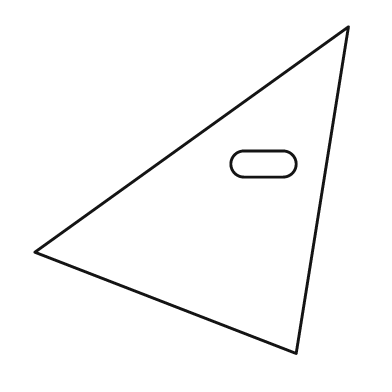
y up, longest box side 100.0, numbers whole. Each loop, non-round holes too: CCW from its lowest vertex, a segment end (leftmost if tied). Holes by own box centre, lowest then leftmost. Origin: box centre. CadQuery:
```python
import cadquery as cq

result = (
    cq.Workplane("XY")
    .moveTo(32.0, -50.0)
    .lineTo(48.0, 50.0)
    .lineTo(-48.0, -19.0)
    .close()
    .moveTo(16.0, 4.0)
    .lineTo(28.0, 4.0)
    .threePointArc((32.0, 8.0), (28.0, 12.0))
    .lineTo(16.0, 12.0)
    .threePointArc((12.0, 8.0), (16.0, 4.0))
    .close()
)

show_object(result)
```